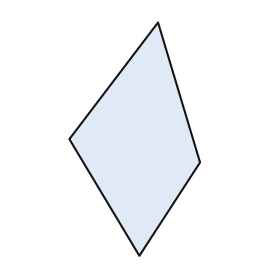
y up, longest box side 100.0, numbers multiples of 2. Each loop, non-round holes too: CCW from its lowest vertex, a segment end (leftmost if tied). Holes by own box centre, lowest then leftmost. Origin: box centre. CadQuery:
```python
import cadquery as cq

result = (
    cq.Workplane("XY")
    .moveTo(2.0, -50.0)
    .lineTo(28.0, -10.0)
    .lineTo(10.0, 50.0)
    .lineTo(-28.0, 0.0)
    .close()
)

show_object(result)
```